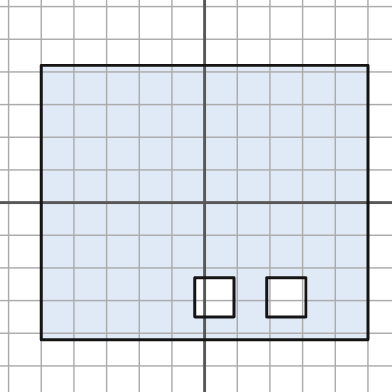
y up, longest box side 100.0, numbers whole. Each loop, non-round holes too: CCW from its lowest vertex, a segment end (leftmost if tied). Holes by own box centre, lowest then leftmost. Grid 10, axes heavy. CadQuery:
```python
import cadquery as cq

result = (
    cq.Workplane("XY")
    .moveTo(-50.0, -42.0)
    .lineTo(50.0, -42.0)
    .lineTo(50.0, 42.0)
    .lineTo(-50.0, 42.0)
    .close()
    .moveTo(-3.0, -35.0)
    .lineTo(9.0, -35.0)
    .lineTo(9.0, -23.0)
    .lineTo(-3.0, -23.0)
    .close()
    .moveTo(19.0, -35.0)
    .lineTo(31.0, -35.0)
    .lineTo(31.0, -23.0)
    .lineTo(19.0, -23.0)
    .close()
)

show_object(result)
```